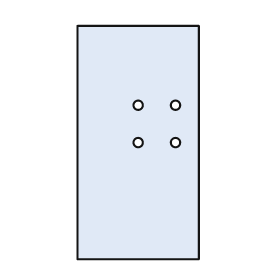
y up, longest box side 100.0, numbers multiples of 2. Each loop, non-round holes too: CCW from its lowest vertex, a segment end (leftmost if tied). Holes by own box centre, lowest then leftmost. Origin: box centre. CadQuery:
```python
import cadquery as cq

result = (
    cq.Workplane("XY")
    .moveTo(-26.0, -50.0)
    .lineTo(26.0, -50.0)
    .lineTo(26.0, 50.0)
    .lineTo(-26.0, 50.0)
    .close()
    .moveTo(0.0, 0.0)
    .circle(2.0)
    .moveTo(16.0, 0.0)
    .circle(2.0)
    .moveTo(0.0, 16.0)
    .circle(2.0)
    .moveTo(16.0, 16.0)
    .circle(2.0)
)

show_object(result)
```